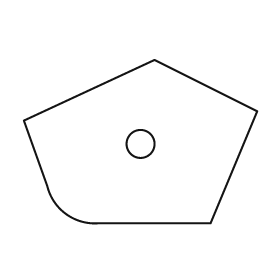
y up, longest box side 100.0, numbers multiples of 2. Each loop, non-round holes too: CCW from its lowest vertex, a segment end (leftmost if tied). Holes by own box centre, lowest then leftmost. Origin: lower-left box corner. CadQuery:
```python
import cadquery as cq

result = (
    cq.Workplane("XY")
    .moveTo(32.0, 0.0)
    .lineTo(80.0, 0.0)
    .lineTo(100.0, 48.0)
    .lineTo(56.0, 70.0)
    .lineTo(0.0, 44.0)
    .lineTo(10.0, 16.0)
    .threePointArc((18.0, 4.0), (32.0, 0.0))
    .close()
    .moveTo(50.0, 34.0)
    .circle(6.0)
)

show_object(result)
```